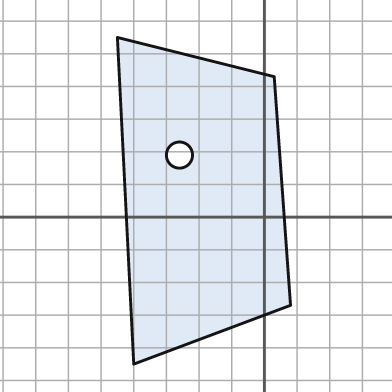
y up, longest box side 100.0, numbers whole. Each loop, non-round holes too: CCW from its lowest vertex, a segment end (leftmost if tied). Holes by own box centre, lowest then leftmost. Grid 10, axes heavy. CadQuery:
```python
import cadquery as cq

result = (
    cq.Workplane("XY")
    .moveTo(-40.0, -45.0)
    .lineTo(8.0, -27.0)
    .lineTo(3.0, 43.0)
    .lineTo(-45.0, 55.0)
    .close()
    .moveTo(-26.0, 19.0)
    .circle(4.0)
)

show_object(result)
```